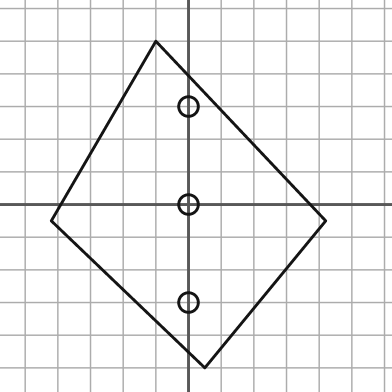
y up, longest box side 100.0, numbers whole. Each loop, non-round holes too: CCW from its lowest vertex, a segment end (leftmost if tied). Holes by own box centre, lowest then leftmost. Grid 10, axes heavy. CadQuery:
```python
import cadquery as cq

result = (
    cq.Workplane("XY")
    .moveTo(5.0, -50.0)
    .lineTo(42.0, -5.0)
    .lineTo(-10.0, 50.0)
    .lineTo(-42.0, -5.0)
    .close()
    .moveTo(0.0, -30.0)
    .circle(3.0)
    .moveTo(0.0, 0.0)
    .circle(3.0)
    .moveTo(0.0, 30.0)
    .circle(3.0)
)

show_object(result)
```